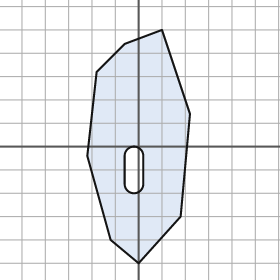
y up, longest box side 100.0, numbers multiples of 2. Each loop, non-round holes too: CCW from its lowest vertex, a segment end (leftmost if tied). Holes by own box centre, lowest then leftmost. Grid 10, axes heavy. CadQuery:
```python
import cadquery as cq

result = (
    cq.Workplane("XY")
    .moveTo(0.0, -50.0)
    .lineTo(18.0, -30.0)
    .lineTo(22.0, 14.0)
    .lineTo(10.0, 50.0)
    .lineTo(-6.0, 44.0)
    .lineTo(-18.0, 32.0)
    .lineTo(-22.0, -4.0)
    .lineTo(-12.0, -40.0)
    .close()
    .moveTo(-6.0, -16.0)
    .threePointArc((-2.0, -20.0), (2.0, -16.0))
    .lineTo(2.0, -4.0)
    .threePointArc((-2.0, 0.0), (-6.0, -4.0))
    .close()
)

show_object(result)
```